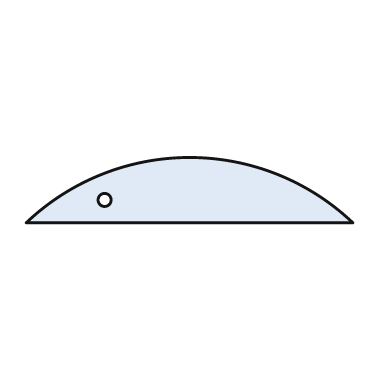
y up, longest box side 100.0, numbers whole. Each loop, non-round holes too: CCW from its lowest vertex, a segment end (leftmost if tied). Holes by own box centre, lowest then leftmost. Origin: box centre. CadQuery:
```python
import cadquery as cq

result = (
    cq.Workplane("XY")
    .moveTo(-50.0, -10.0)
    .lineTo(50.0, -10.0)
    .threePointArc((0.0, 10.0), (-50.0, -10.0))
    .close()
    .moveTo(-26.0, -3.0)
    .circle(2.0)
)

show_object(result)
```